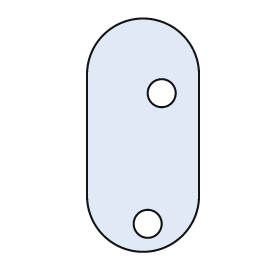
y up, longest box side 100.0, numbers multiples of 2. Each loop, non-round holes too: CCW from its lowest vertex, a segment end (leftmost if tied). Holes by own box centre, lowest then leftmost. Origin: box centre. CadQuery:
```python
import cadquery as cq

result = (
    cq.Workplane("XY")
    .moveTo(-24.0, -26.0)
    .threePointArc((0.0, -50.0), (24.0, -26.0))
    .lineTo(24.0, 26.0)
    .threePointArc((0.0, 50.0), (-24.0, 26.0))
    .close()
    .moveTo(2.0, -38.0)
    .circle(6.0)
    .moveTo(8.0, 18.0)
    .circle(6.0)
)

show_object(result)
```